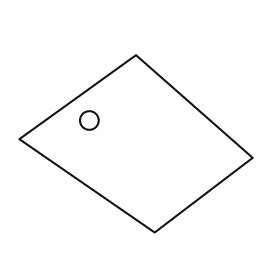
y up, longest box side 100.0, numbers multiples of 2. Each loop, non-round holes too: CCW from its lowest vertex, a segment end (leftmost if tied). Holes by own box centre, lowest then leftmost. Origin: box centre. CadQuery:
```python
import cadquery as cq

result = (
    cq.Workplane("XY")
    .moveTo(8.0, -38.0)
    .lineTo(50.0, -6.0)
    .lineTo(0.0, 38.0)
    .lineTo(-50.0, 2.0)
    .close()
    .moveTo(-20.0, 10.0)
    .circle(4.0)
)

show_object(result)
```